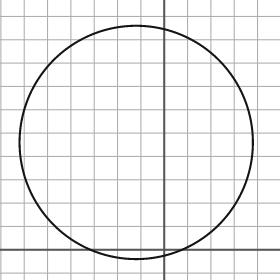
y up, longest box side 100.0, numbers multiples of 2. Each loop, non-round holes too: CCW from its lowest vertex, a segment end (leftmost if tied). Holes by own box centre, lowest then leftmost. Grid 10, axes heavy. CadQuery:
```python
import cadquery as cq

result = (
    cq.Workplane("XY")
    .moveTo(-12.0, 46.0)
    .circle(50.0)
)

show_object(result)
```